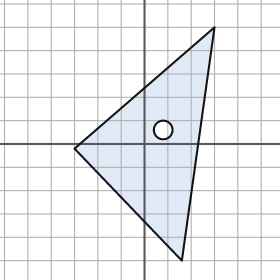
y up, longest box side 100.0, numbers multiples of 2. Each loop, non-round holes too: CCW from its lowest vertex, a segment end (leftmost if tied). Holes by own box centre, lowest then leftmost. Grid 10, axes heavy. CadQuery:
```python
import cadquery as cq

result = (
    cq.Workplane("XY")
    .moveTo(16.0, -50.0)
    .lineTo(30.0, 50.0)
    .lineTo(-30.0, -2.0)
    .close()
    .moveTo(8.0, 6.0)
    .circle(4.0)
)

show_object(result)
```